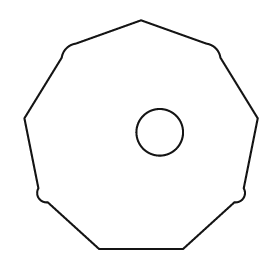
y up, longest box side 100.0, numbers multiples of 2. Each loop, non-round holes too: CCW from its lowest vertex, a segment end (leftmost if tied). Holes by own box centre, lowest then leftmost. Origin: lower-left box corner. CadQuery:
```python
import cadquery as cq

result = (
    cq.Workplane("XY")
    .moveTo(32.0, 0.0)
    .lineTo(68.0, 0.0)
    .lineTo(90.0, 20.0)
    .threePointArc((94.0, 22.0), (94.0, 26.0))
    .lineTo(100.0, 56.0)
    .lineTo(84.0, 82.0)
    .threePointArc((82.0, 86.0), (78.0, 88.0))
    .lineTo(50.0, 98.0)
    .lineTo(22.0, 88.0)
    .threePointArc((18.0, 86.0), (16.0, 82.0))
    .lineTo(0.0, 56.0)
    .lineTo(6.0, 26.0)
    .threePointArc((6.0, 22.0), (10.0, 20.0))
    .close()
    .moveTo(58.0, 50.0)
    .circle(10.0)
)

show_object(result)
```